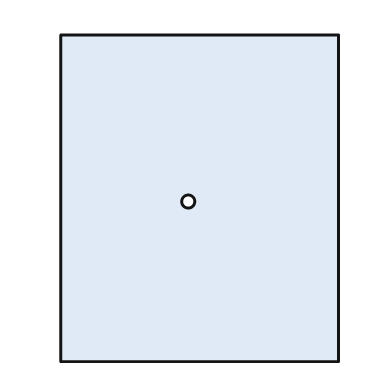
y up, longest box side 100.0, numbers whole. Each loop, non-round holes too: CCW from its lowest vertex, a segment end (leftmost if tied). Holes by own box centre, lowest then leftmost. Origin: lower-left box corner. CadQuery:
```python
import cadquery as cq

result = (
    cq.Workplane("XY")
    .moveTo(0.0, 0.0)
    .lineTo(85.0, 0.0)
    .lineTo(85.0, 100.0)
    .lineTo(0.0, 100.0)
    .close()
    .moveTo(39.0, 49.0)
    .circle(2.0)
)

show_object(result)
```